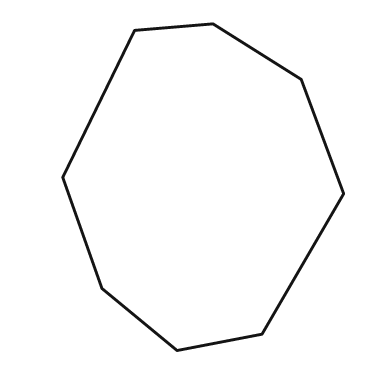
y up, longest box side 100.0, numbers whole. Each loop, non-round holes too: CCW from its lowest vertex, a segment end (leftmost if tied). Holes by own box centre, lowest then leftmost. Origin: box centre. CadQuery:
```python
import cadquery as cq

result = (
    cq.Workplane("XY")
    .moveTo(-8.0, -50.0)
    .lineTo(18.0, -45.0)
    .lineTo(43.0, -2.0)
    .lineTo(30.0, 33.0)
    .lineTo(3.0, 50.0)
    .lineTo(-21.0, 48.0)
    .lineTo(-43.0, 3.0)
    .lineTo(-31.0, -31.0)
    .close()
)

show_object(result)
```